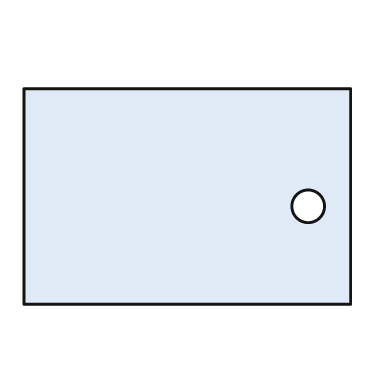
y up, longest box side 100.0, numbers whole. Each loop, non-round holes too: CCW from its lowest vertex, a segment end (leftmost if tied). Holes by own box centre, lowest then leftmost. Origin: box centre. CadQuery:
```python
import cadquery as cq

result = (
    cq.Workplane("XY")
    .moveTo(-50.0, -33.0)
    .lineTo(50.0, -33.0)
    .lineTo(50.0, 33.0)
    .lineTo(-50.0, 33.0)
    .close()
    .moveTo(37.0, -3.0)
    .circle(5.0)
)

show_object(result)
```